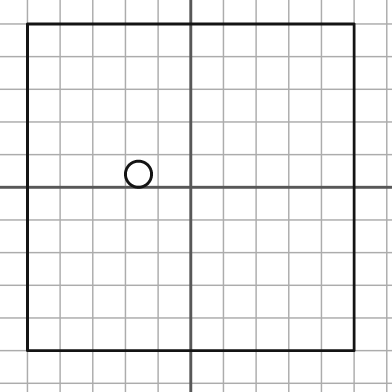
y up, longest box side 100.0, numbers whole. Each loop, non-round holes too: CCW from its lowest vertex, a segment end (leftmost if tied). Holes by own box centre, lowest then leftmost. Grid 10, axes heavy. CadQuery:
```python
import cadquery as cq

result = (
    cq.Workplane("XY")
    .moveTo(-50.0, -50.0)
    .lineTo(50.0, -50.0)
    .lineTo(50.0, 50.0)
    .lineTo(-50.0, 50.0)
    .close()
    .moveTo(-16.0, 4.0)
    .circle(4.0)
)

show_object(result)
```